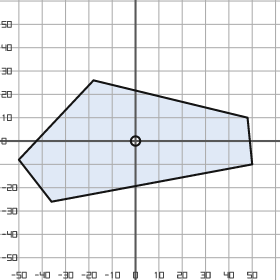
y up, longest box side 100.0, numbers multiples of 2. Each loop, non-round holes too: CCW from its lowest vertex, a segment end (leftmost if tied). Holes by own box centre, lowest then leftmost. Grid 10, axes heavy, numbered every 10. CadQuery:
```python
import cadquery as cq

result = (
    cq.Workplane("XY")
    .moveTo(-36.0, -26.0)
    .lineTo(50.0, -10.0)
    .lineTo(48.0, 10.0)
    .lineTo(-18.0, 26.0)
    .lineTo(-50.0, -8.0)
    .close()
    .moveTo(0.0, 0.0)
    .circle(2.0)
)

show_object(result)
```